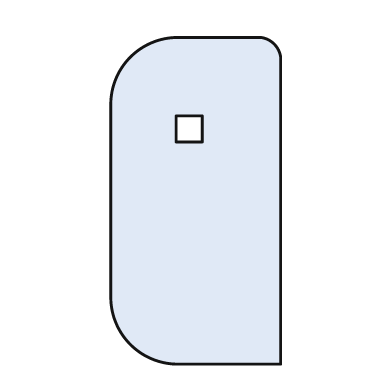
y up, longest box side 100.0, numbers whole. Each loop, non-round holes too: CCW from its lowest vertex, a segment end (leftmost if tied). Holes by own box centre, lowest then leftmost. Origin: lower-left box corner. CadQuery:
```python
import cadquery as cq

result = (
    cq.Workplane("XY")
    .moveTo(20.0, 0.0)
    .lineTo(52.0, 0.0)
    .lineTo(52.0, 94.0)
    .threePointArc((50.0, 98.0), (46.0, 100.0))
    .lineTo(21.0, 100.0)
    .threePointArc((6.0, 94.0), (0.0, 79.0))
    .lineTo(0.0, 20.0)
    .threePointArc((6.0, 6.0), (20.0, 0.0))
    .close()
    .moveTo(20.0, 68.0)
    .lineTo(28.0, 68.0)
    .lineTo(28.0, 76.0)
    .lineTo(20.0, 76.0)
    .close()
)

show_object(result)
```